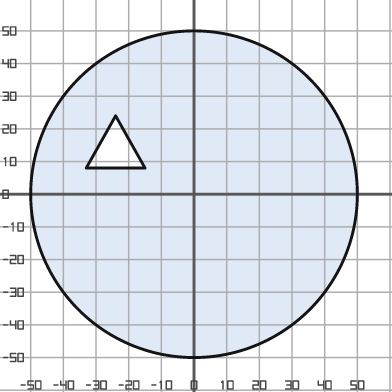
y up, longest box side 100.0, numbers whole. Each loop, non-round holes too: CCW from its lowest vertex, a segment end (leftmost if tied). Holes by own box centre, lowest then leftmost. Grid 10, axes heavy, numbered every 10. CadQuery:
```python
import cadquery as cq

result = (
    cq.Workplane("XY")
    .moveTo(0.0, 0.0)
    .circle(50.0)
    .moveTo(-33.0, 8.0)
    .lineTo(-15.0, 8.0)
    .lineTo(-24.0, 24.0)
    .close()
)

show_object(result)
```